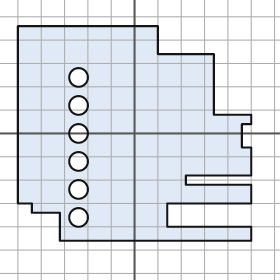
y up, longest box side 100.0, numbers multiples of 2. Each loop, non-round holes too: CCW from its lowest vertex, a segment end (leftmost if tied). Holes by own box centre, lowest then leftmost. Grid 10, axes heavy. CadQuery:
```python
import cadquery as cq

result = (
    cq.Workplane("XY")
    .moveTo(-32.0, -46.0)
    .lineTo(50.0, -46.0)
    .lineTo(50.0, -40.0)
    .lineTo(14.0, -40.0)
    .lineTo(14.0, -30.0)
    .lineTo(50.0, -30.0)
    .lineTo(50.0, -22.0)
    .lineTo(22.0, -22.0)
    .lineTo(22.0, -18.0)
    .lineTo(50.0, -18.0)
    .lineTo(50.0, -6.0)
    .lineTo(46.0, -6.0)
    .lineTo(46.0, 4.0)
    .lineTo(50.0, 4.0)
    .lineTo(50.0, 8.0)
    .lineTo(34.0, 8.0)
    .lineTo(34.0, 34.0)
    .lineTo(10.0, 34.0)
    .lineTo(10.0, 46.0)
    .lineTo(-50.0, 46.0)
    .lineTo(-50.0, -30.0)
    .lineTo(-44.0, -30.0)
    .lineTo(-44.0, -34.0)
    .lineTo(-32.0, -34.0)
    .close()
    .moveTo(-24.0, -36.0)
    .circle(4.0)
    .moveTo(-24.0, -24.0)
    .circle(4.0)
    .moveTo(-24.0, -12.0)
    .circle(4.0)
    .moveTo(-24.0, 0.0)
    .circle(4.0)
    .moveTo(-24.0, 12.0)
    .circle(4.0)
    .moveTo(-24.0, 24.0)
    .circle(4.0)
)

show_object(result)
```